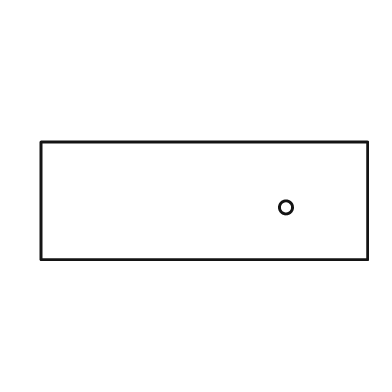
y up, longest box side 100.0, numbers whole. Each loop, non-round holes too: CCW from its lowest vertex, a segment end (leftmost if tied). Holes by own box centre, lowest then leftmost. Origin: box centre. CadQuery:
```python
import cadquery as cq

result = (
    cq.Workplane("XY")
    .moveTo(-50.0, -18.0)
    .lineTo(50.0, -18.0)
    .lineTo(50.0, 18.0)
    .lineTo(-50.0, 18.0)
    .close()
    .moveTo(25.0, -2.0)
    .circle(2.0)
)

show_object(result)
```